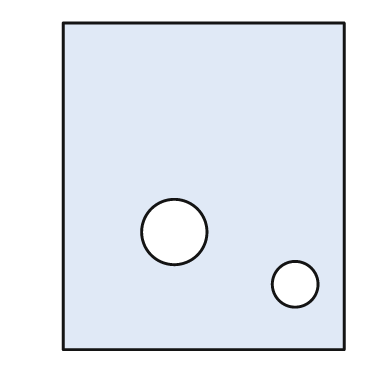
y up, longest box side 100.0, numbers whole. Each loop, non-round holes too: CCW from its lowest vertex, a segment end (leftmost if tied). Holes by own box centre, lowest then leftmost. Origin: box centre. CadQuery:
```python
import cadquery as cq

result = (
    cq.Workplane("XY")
    .moveTo(-43.0, -50.0)
    .lineTo(43.0, -50.0)
    .lineTo(43.0, 50.0)
    .lineTo(-43.0, 50.0)
    .close()
    .moveTo(28.0, -30.0)
    .circle(7.0)
    .moveTo(-9.0, -14.0)
    .circle(10.0)
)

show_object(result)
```